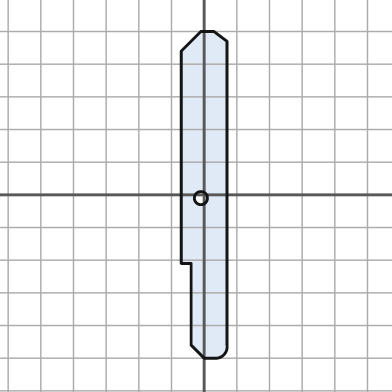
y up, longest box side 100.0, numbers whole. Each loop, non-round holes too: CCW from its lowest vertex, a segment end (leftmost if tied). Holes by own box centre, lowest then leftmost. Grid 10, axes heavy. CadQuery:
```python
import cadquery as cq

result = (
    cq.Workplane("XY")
    .moveTo(0.0, -50.0)
    .lineTo(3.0, -50.0)
    .threePointArc((6.0, -49.0), (7.0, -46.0))
    .lineTo(7.0, 47.0)
    .lineTo(3.0, 50.0)
    .lineTo(-1.0, 50.0)
    .lineTo(-7.0, 44.0)
    .lineTo(-7.0, -21.0)
    .lineTo(-4.0, -21.0)
    .lineTo(-4.0, -46.0)
    .close()
    .moveTo(-1.0, -1.0)
    .circle(2.0)
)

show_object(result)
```